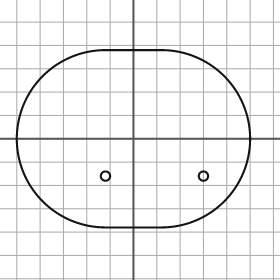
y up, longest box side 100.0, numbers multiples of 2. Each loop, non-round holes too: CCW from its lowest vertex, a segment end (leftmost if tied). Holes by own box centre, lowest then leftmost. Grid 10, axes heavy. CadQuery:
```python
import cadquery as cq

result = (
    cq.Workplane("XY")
    .moveTo(-12.0, -38.0)
    .lineTo(12.0, -38.0)
    .threePointArc((50.0, 0.0), (12.0, 38.0))
    .lineTo(-12.0, 38.0)
    .threePointArc((-50.0, 0.0), (-12.0, -38.0))
    .close()
    .moveTo(-12.0, -16.0)
    .circle(2.0)
    .moveTo(30.0, -16.0)
    .circle(2.0)
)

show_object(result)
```